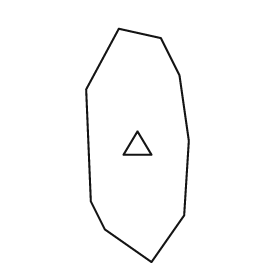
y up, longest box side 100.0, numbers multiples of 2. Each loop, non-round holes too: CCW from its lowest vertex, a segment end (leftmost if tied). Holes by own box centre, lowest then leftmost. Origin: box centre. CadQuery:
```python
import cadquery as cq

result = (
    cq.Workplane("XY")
    .moveTo(6.0, -50.0)
    .lineTo(20.0, -30.0)
    .lineTo(22.0, 2.0)
    .lineTo(18.0, 30.0)
    .lineTo(10.0, 46.0)
    .lineTo(-8.0, 50.0)
    .lineTo(-22.0, 24.0)
    .lineTo(-20.0, -24.0)
    .lineTo(-14.0, -36.0)
    .close()
    .moveTo(-6.0, -4.0)
    .lineTo(6.0, -4.0)
    .lineTo(0.0, 6.0)
    .close()
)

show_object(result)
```